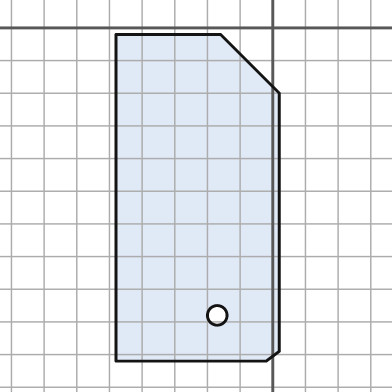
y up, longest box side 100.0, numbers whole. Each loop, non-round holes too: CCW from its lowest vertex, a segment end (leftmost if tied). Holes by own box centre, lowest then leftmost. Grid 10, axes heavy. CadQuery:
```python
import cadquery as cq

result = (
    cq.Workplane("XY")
    .moveTo(-48.0, -102.0)
    .lineTo(-2.0, -102.0)
    .lineTo(2.0, -99.0)
    .lineTo(2.0, -20.0)
    .lineTo(-16.0, -2.0)
    .lineTo(-48.0, -2.0)
    .close()
    .moveTo(-17.0, -88.0)
    .circle(3.0)
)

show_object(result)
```